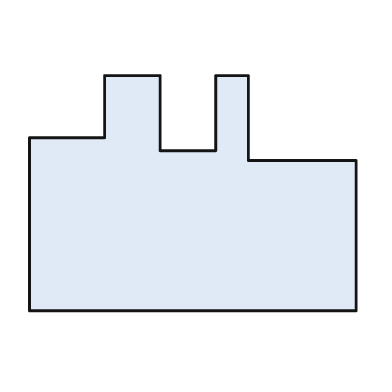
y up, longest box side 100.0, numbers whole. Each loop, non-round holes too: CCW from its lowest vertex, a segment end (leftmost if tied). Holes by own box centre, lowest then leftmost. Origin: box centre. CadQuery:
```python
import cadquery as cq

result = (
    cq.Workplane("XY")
    .moveTo(-50.0, -36.0)
    .lineTo(50.0, -36.0)
    .lineTo(50.0, 10.0)
    .lineTo(17.0, 10.0)
    .lineTo(17.0, 36.0)
    .lineTo(7.0, 36.0)
    .lineTo(7.0, 13.0)
    .lineTo(-10.0, 13.0)
    .lineTo(-10.0, 36.0)
    .lineTo(-27.0, 36.0)
    .lineTo(-27.0, 17.0)
    .lineTo(-50.0, 17.0)
    .close()
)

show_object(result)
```